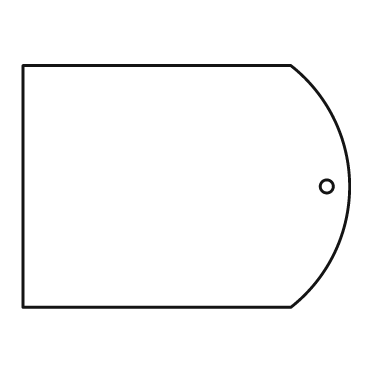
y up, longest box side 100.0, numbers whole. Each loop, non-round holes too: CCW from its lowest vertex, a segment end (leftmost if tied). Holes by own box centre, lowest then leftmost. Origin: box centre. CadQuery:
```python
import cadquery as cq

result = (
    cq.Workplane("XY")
    .moveTo(-50.0, -37.0)
    .lineTo(32.0, -37.0)
    .threePointArc((50.0, 0.0), (32.0, 37.0))
    .lineTo(-50.0, 37.0)
    .close()
    .moveTo(43.0, 0.0)
    .circle(2.0)
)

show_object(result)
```